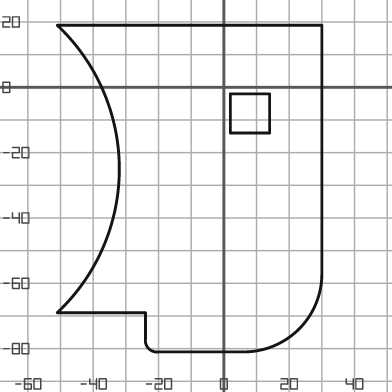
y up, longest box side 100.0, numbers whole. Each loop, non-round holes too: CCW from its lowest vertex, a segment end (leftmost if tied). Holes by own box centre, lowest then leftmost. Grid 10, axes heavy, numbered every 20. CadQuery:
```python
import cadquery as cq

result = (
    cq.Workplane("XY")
    .moveTo(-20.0, -81.0)
    .lineTo(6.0, -81.0)
    .threePointArc((23.0, -74.0), (30.0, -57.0))
    .lineTo(30.0, 19.0)
    .lineTo(-51.0, 19.0)
    .threePointArc((-32.0, -25.0), (-51.0, -69.0))
    .lineTo(-24.0, -69.0)
    .lineTo(-24.0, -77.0)
    .threePointArc((-23.0, -80.0), (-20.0, -81.0))
    .close()
    .moveTo(2.0, -14.0)
    .lineTo(14.0, -14.0)
    .lineTo(14.0, -2.0)
    .lineTo(2.0, -2.0)
    .close()
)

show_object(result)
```